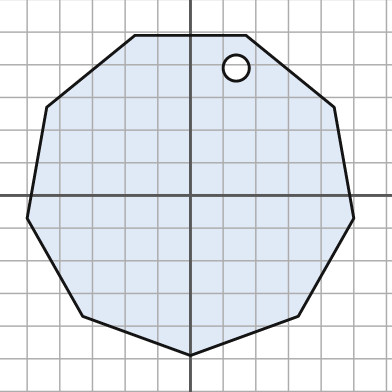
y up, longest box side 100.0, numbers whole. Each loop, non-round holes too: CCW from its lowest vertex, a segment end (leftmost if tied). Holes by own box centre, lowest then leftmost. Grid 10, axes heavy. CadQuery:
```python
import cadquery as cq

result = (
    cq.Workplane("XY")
    .moveTo(0.0, -49.0)
    .lineTo(33.0, -37.0)
    .lineTo(50.0, -7.0)
    .lineTo(44.0, 27.0)
    .lineTo(17.0, 49.0)
    .lineTo(-17.0, 49.0)
    .lineTo(-44.0, 27.0)
    .lineTo(-50.0, -7.0)
    .lineTo(-33.0, -37.0)
    .close()
    .moveTo(14.0, 39.0)
    .circle(4.0)
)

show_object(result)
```